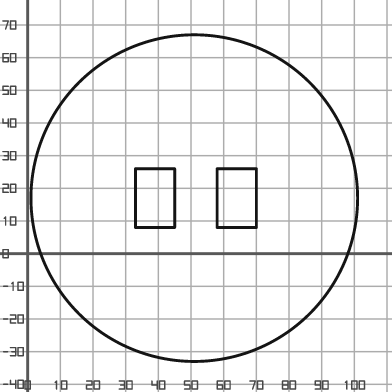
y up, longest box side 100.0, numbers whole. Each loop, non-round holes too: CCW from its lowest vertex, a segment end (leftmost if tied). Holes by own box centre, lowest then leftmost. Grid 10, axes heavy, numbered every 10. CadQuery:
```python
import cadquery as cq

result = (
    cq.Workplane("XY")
    .moveTo(51.0, 17.0)
    .circle(50.0)
    .moveTo(33.0, 8.0)
    .lineTo(45.0, 8.0)
    .lineTo(45.0, 26.0)
    .lineTo(33.0, 26.0)
    .close()
    .moveTo(58.0, 8.0)
    .lineTo(70.0, 8.0)
    .lineTo(70.0, 26.0)
    .lineTo(58.0, 26.0)
    .close()
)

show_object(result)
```